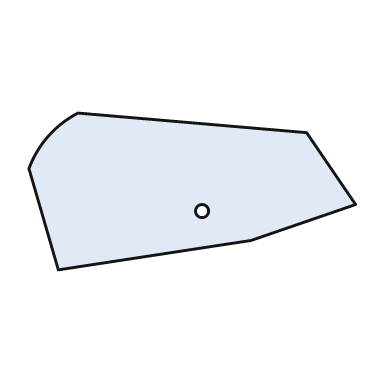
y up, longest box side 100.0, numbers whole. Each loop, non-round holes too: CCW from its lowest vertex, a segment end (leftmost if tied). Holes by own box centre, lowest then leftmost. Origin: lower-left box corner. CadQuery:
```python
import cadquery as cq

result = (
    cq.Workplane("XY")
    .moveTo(9.0, 0.0)
    .lineTo(68.0, 9.0)
    .lineTo(100.0, 20.0)
    .lineTo(85.0, 42.0)
    .lineTo(15.0, 48.0)
    .threePointArc((6.0, 41.0), (0.0, 31.0))
    .close()
    .moveTo(53.0, 18.0)
    .circle(2.0)
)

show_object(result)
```